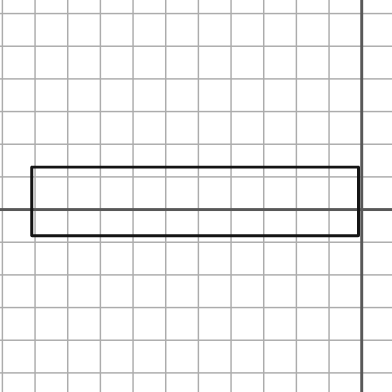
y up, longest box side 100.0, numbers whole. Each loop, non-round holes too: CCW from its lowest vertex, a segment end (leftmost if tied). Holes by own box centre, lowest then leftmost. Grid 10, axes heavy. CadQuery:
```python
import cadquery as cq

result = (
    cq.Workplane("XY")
    .moveTo(-101.0, -8.0)
    .lineTo(-1.0, -8.0)
    .lineTo(-1.0, 13.0)
    .lineTo(-101.0, 13.0)
    .close()
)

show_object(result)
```